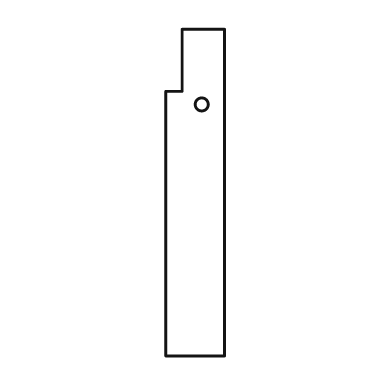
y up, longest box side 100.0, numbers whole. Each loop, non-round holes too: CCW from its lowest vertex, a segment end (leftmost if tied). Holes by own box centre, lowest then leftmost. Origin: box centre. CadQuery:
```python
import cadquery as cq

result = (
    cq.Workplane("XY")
    .moveTo(-9.0, -50.0)
    .lineTo(9.0, -50.0)
    .lineTo(9.0, 50.0)
    .lineTo(-4.0, 50.0)
    .lineTo(-4.0, 31.0)
    .lineTo(-9.0, 31.0)
    .close()
    .moveTo(2.0, 27.0)
    .circle(2.0)
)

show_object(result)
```